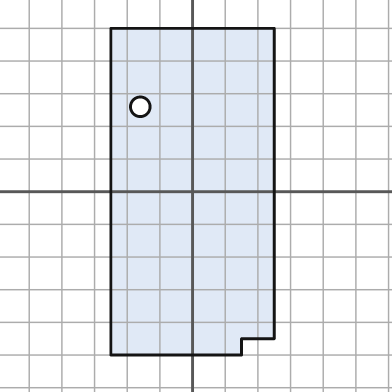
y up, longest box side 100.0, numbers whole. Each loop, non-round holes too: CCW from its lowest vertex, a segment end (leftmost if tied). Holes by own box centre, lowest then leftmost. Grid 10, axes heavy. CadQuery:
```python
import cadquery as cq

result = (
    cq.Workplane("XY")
    .moveTo(-25.0, -50.0)
    .lineTo(15.0, -50.0)
    .lineTo(15.0, -45.0)
    .lineTo(25.0, -45.0)
    .lineTo(25.0, 50.0)
    .lineTo(-25.0, 50.0)
    .close()
    .moveTo(-16.0, 26.0)
    .circle(3.0)
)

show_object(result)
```